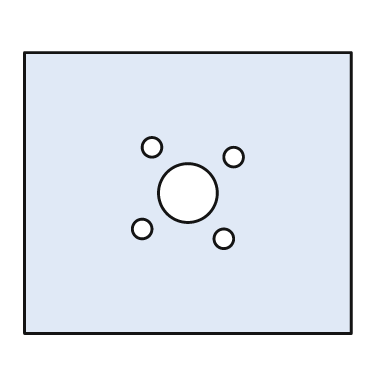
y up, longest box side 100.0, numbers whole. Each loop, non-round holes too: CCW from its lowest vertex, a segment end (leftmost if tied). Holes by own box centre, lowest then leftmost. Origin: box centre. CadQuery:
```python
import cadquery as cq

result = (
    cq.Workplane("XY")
    .moveTo(-50.0, -43.0)
    .lineTo(50.0, -43.0)
    .lineTo(50.0, 43.0)
    .lineTo(-50.0, 43.0)
    .close()
    .moveTo(11.0, -14.0)
    .circle(3.0)
    .moveTo(-14.0, -11.0)
    .circle(3.0)
    .moveTo(0.0, 0.0)
    .circle(9.0)
    .moveTo(14.0, 11.0)
    .circle(3.0)
    .moveTo(-11.0, 14.0)
    .circle(3.0)
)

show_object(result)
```